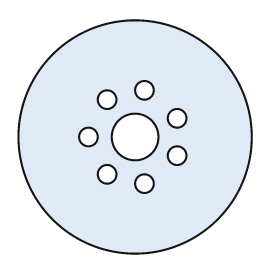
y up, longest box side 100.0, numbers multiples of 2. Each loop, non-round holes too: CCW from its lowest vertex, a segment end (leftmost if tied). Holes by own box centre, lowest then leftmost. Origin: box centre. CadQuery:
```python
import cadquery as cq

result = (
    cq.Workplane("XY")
    .moveTo(0.0, 0.0)
    .circle(50.0)
    .moveTo(4.0, -20.0)
    .circle(4.0)
    .moveTo(-12.0, -16.0)
    .circle(4.0)
    .moveTo(18.0, -8.0)
    .circle(4.0)
    .moveTo(-20.0, 0.0)
    .circle(4.0)
    .moveTo(0.0, 0.0)
    .circle(10.0)
    .moveTo(18.0, 8.0)
    .circle(4.0)
    .moveTo(-12.0, 16.0)
    .circle(4.0)
    .moveTo(4.0, 20.0)
    .circle(4.0)
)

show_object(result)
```